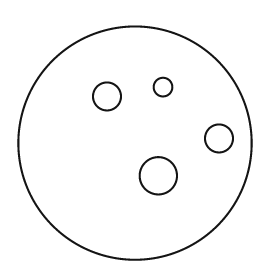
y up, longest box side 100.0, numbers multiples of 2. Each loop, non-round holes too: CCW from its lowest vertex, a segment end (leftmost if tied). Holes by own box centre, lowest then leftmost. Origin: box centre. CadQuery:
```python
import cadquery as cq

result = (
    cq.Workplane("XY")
    .moveTo(0.0, 0.0)
    .circle(50.0)
    .moveTo(10.0, -14.0)
    .circle(8.0)
    .moveTo(36.0, 2.0)
    .circle(6.0)
    .moveTo(-12.0, 20.0)
    .circle(6.0)
    .moveTo(12.0, 24.0)
    .circle(4.0)
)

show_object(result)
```